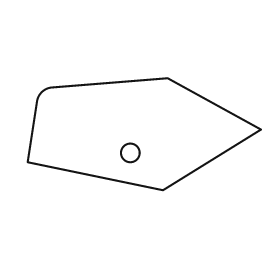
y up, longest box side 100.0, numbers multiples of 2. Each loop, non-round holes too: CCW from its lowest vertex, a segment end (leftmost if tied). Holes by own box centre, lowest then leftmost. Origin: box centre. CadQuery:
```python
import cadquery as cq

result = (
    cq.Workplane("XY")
    .moveTo(8.0, -24.0)
    .lineTo(50.0, 2.0)
    .lineTo(10.0, 24.0)
    .lineTo(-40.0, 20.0)
    .threePointArc((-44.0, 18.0), (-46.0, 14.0))
    .lineTo(-50.0, -12.0)
    .close()
    .moveTo(-6.0, -8.0)
    .circle(4.0)
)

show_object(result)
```